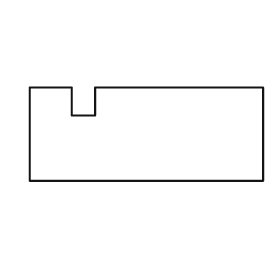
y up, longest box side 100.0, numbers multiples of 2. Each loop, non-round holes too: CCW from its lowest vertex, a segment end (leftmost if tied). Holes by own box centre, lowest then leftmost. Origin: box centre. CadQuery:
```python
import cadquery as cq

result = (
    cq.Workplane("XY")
    .moveTo(-50.0, -20.0)
    .lineTo(50.0, -20.0)
    .lineTo(50.0, 20.0)
    .lineTo(-22.0, 20.0)
    .lineTo(-22.0, 8.0)
    .lineTo(-32.0, 8.0)
    .lineTo(-32.0, 20.0)
    .lineTo(-50.0, 20.0)
    .close()
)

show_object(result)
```